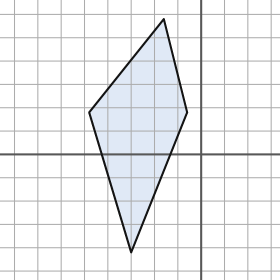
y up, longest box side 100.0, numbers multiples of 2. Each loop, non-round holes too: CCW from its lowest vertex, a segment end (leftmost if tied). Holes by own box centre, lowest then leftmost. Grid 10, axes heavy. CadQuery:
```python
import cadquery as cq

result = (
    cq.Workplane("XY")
    .moveTo(-30.0, -42.0)
    .lineTo(-6.0, 18.0)
    .lineTo(-16.0, 58.0)
    .lineTo(-48.0, 18.0)
    .close()
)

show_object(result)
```